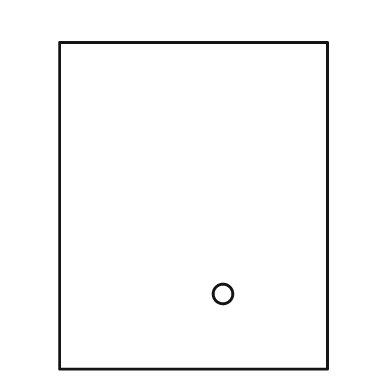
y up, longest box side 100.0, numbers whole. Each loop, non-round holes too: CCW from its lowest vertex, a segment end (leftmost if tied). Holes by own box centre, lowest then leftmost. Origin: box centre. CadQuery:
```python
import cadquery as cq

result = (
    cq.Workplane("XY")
    .moveTo(-41.0, -50.0)
    .lineTo(41.0, -50.0)
    .lineTo(41.0, 50.0)
    .lineTo(-41.0, 50.0)
    .close()
    .moveTo(9.0, -27.0)
    .circle(3.0)
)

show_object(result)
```